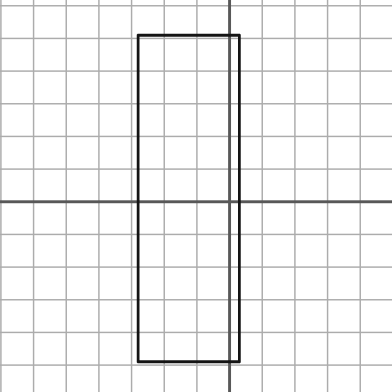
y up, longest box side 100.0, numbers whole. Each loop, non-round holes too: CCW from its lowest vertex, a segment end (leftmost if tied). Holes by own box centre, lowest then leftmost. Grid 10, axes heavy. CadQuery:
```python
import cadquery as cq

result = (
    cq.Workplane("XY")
    .moveTo(-28.0, -49.0)
    .lineTo(3.0, -49.0)
    .lineTo(3.0, 51.0)
    .lineTo(-28.0, 51.0)
    .close()
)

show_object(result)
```